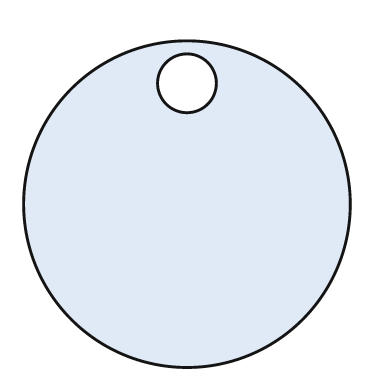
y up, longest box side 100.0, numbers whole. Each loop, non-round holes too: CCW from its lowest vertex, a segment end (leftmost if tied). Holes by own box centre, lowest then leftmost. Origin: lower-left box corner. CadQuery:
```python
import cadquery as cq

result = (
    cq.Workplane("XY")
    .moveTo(50.0, 50.0)
    .circle(50.0)
    .moveTo(50.0, 87.0)
    .circle(9.0)
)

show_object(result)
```